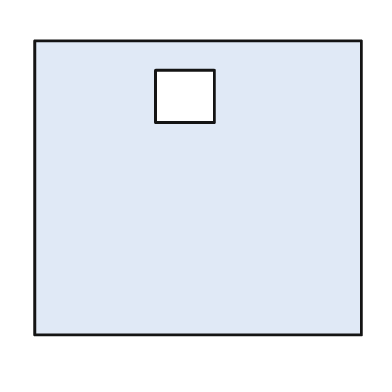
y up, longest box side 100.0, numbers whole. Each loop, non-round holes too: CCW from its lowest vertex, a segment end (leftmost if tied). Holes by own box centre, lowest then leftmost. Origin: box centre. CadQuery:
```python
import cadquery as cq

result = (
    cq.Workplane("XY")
    .moveTo(-50.0, -45.0)
    .lineTo(50.0, -45.0)
    .lineTo(50.0, 45.0)
    .lineTo(-50.0, 45.0)
    .close()
    .moveTo(-13.0, 20.0)
    .lineTo(5.0, 20.0)
    .lineTo(5.0, 36.0)
    .lineTo(-13.0, 36.0)
    .close()
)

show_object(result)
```